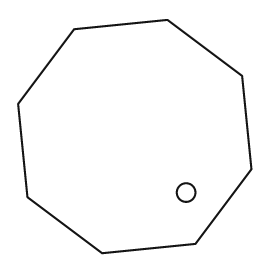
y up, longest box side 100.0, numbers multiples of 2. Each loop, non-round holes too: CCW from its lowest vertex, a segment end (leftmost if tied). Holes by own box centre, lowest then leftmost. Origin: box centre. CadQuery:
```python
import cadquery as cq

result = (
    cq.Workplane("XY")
    .moveTo(-14.0, -50.0)
    .lineTo(26.0, -46.0)
    .lineTo(50.0, -14.0)
    .lineTo(46.0, 26.0)
    .lineTo(14.0, 50.0)
    .lineTo(-26.0, 46.0)
    .lineTo(-50.0, 14.0)
    .lineTo(-46.0, -26.0)
    .close()
    .moveTo(22.0, -24.0)
    .circle(4.0)
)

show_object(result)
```